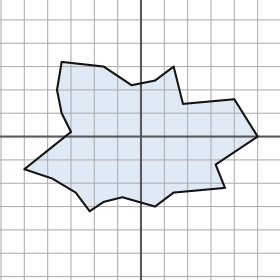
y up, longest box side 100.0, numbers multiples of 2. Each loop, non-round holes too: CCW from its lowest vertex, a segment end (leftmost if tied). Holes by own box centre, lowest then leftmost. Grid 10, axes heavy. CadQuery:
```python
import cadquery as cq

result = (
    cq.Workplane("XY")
    .moveTo(-22.0, -32.0)
    .lineTo(-16.0, -28.0)
    .lineTo(-8.0, -26.0)
    .lineTo(6.0, -30.0)
    .lineTo(14.0, -24.0)
    .lineTo(36.0, -22.0)
    .lineTo(32.0, -12.0)
    .lineTo(50.0, 0.0)
    .lineTo(40.0, 16.0)
    .lineTo(18.0, 14.0)
    .lineTo(14.0, 30.0)
    .lineTo(6.0, 24.0)
    .lineTo(-4.0, 22.0)
    .lineTo(-16.0, 30.0)
    .lineTo(-34.0, 32.0)
    .lineTo(-36.0, 20.0)
    .lineTo(-34.0, 10.0)
    .lineTo(-30.0, 2.0)
    .lineTo(-50.0, -14.0)
    .lineTo(-38.0, -18.0)
    .lineTo(-28.0, -24.0)
    .close()
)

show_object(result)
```